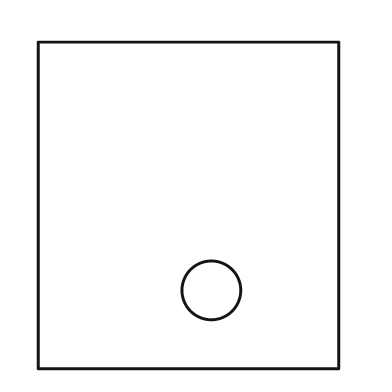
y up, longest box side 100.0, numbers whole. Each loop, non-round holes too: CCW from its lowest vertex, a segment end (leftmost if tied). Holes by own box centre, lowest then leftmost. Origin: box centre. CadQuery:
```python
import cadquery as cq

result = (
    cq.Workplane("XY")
    .moveTo(-46.0, -50.0)
    .lineTo(46.0, -50.0)
    .lineTo(46.0, 50.0)
    .lineTo(-46.0, 50.0)
    .close()
    .moveTo(7.0, -26.0)
    .circle(9.0)
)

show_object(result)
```